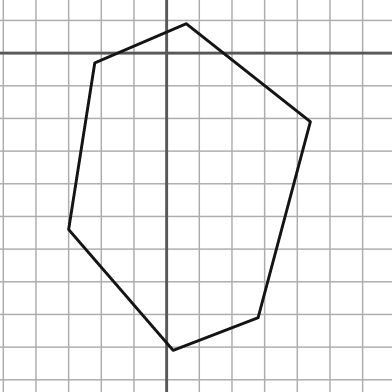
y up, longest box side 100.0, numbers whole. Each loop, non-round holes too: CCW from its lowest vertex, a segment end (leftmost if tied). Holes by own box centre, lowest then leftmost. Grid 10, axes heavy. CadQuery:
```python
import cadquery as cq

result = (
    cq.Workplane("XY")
    .moveTo(2.0, -91.0)
    .lineTo(28.0, -81.0)
    .lineTo(44.0, -21.0)
    .lineTo(6.0, 9.0)
    .lineTo(-22.0, -3.0)
    .lineTo(-30.0, -54.0)
    .close()
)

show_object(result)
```